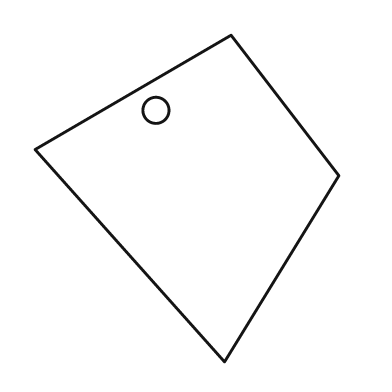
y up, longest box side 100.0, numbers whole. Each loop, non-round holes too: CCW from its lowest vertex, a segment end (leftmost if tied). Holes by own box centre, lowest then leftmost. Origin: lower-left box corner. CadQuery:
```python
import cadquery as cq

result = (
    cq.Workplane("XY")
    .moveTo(58.0, 0.0)
    .lineTo(93.0, 57.0)
    .lineTo(60.0, 100.0)
    .lineTo(0.0, 65.0)
    .close()
    .moveTo(37.0, 77.0)
    .circle(4.0)
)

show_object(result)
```